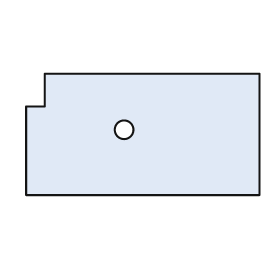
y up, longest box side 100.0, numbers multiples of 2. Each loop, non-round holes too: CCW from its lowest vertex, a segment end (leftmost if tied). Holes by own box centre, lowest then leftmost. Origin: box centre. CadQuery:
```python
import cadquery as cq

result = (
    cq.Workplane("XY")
    .moveTo(-50.0, -26.0)
    .lineTo(50.0, -26.0)
    .lineTo(50.0, 26.0)
    .lineTo(-42.0, 26.0)
    .lineTo(-42.0, 12.0)
    .lineTo(-50.0, 12.0)
    .close()
    .moveTo(-8.0, 2.0)
    .circle(4.0)
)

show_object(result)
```